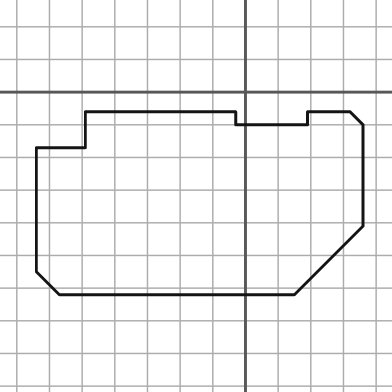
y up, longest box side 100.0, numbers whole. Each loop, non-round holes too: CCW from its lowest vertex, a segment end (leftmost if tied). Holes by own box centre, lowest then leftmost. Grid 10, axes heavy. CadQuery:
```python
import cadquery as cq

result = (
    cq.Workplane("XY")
    .moveTo(-57.0, -62.0)
    .lineTo(15.0, -62.0)
    .lineTo(36.0, -41.0)
    .lineTo(36.0, -10.0)
    .lineTo(32.0, -6.0)
    .lineTo(19.0, -6.0)
    .lineTo(19.0, -10.0)
    .lineTo(-3.0, -10.0)
    .lineTo(-3.0, -6.0)
    .lineTo(-49.0, -6.0)
    .lineTo(-49.0, -17.0)
    .lineTo(-64.0, -17.0)
    .lineTo(-64.0, -55.0)
    .close()
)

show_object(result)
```